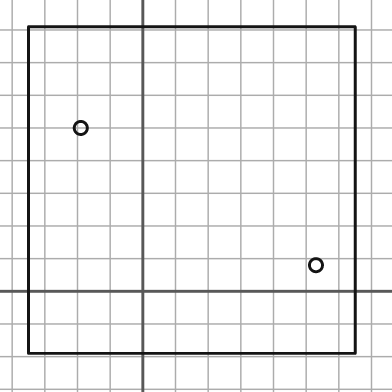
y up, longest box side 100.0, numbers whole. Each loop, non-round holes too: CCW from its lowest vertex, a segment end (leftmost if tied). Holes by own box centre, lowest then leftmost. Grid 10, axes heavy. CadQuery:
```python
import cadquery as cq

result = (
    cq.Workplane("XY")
    .moveTo(-35.0, -19.0)
    .lineTo(65.0, -19.0)
    .lineTo(65.0, 81.0)
    .lineTo(-35.0, 81.0)
    .close()
    .moveTo(53.0, 8.0)
    .circle(2.0)
    .moveTo(-19.0, 50.0)
    .circle(2.0)
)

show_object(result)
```